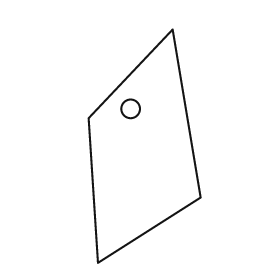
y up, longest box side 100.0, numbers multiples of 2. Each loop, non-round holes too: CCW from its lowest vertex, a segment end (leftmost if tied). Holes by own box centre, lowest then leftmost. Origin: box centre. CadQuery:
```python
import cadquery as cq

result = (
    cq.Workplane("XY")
    .moveTo(-20.0, -50.0)
    .lineTo(24.0, -22.0)
    .lineTo(12.0, 50.0)
    .lineTo(-24.0, 12.0)
    .close()
    .moveTo(-6.0, 16.0)
    .circle(4.0)
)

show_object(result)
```